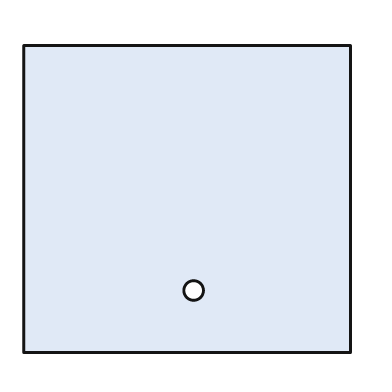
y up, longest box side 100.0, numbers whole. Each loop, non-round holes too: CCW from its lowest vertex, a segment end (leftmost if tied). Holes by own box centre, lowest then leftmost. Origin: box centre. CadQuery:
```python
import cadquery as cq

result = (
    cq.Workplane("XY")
    .moveTo(-50.0, -47.0)
    .lineTo(50.0, -47.0)
    .lineTo(50.0, 47.0)
    .lineTo(-50.0, 47.0)
    .close()
    .moveTo(2.0, -28.0)
    .circle(3.0)
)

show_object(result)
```